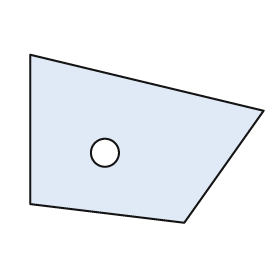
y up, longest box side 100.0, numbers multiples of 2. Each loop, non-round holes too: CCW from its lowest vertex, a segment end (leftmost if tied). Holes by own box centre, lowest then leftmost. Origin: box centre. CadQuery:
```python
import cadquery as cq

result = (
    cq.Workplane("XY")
    .moveTo(16.0, -36.0)
    .lineTo(50.0, 12.0)
    .lineTo(-50.0, 36.0)
    .lineTo(-50.0, -28.0)
    .close()
    .moveTo(-18.0, -6.0)
    .circle(6.0)
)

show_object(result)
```